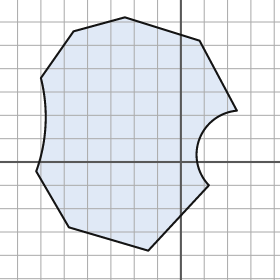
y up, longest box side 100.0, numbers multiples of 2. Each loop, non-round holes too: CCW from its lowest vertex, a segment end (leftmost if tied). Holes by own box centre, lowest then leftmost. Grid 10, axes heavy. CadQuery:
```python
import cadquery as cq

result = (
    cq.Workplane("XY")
    .moveTo(-14.0, -38.0)
    .lineTo(12.0, -10.0)
    .threePointArc((8.0, 10.0), (24.0, 22.0))
    .lineTo(8.0, 52.0)
    .lineTo(-24.0, 62.0)
    .lineTo(-46.0, 56.0)
    .lineTo(-60.0, 36.0)
    .threePointArc((-58.0, 16.0), (-62.0, -4.0))
    .lineTo(-48.0, -28.0)
    .close()
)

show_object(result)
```